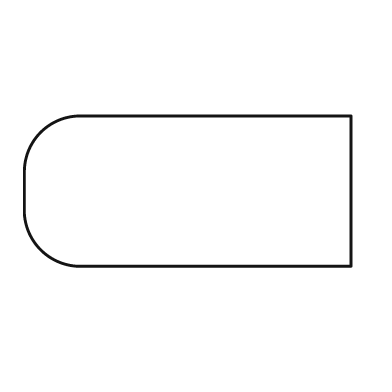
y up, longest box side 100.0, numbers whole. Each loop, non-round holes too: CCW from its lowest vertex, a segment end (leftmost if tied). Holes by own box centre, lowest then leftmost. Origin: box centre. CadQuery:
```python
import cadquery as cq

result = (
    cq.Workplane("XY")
    .moveTo(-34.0, -23.0)
    .lineTo(50.0, -23.0)
    .lineTo(50.0, 23.0)
    .lineTo(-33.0, 23.0)
    .threePointArc((-45.0, 18.0), (-50.0, 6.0))
    .lineTo(-50.0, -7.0)
    .threePointArc((-45.0, -18.0), (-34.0, -23.0))
    .close()
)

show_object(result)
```